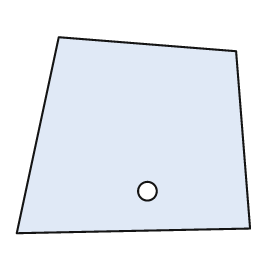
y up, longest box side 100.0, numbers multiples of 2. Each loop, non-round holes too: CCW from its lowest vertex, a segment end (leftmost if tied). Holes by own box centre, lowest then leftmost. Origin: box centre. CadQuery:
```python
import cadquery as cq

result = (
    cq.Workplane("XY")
    .moveTo(-50.0, -42.0)
    .lineTo(50.0, -40.0)
    .lineTo(44.0, 36.0)
    .lineTo(-32.0, 42.0)
    .close()
    .moveTo(6.0, -24.0)
    .circle(4.0)
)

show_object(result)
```